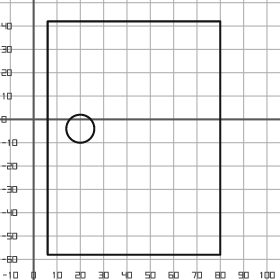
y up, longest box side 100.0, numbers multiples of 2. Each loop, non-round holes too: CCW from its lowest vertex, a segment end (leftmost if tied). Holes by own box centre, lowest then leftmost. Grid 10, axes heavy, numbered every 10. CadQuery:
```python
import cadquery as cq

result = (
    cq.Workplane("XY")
    .moveTo(6.0, -58.0)
    .lineTo(80.0, -58.0)
    .lineTo(80.0, 42.0)
    .lineTo(6.0, 42.0)
    .close()
    .moveTo(20.0, -4.0)
    .circle(6.0)
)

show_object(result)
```